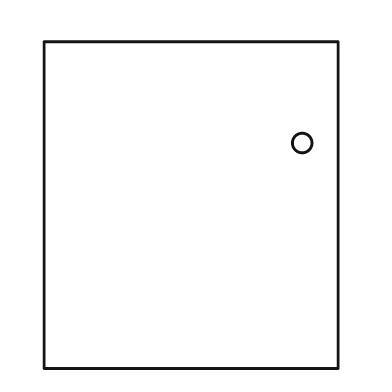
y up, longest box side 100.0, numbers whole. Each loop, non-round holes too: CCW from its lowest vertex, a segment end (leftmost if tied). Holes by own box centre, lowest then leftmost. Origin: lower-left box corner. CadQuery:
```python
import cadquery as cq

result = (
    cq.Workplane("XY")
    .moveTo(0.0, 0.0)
    .lineTo(90.0, 0.0)
    .lineTo(90.0, 100.0)
    .lineTo(0.0, 100.0)
    .close()
    .moveTo(79.0, 69.0)
    .circle(3.0)
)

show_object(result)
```